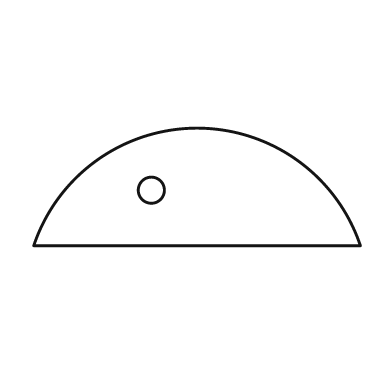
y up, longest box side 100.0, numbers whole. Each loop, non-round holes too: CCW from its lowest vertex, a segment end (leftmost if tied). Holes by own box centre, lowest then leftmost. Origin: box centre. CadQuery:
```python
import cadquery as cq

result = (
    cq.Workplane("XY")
    .moveTo(-50.0, -18.0)
    .lineTo(50.0, -18.0)
    .threePointArc((0.0, 18.0), (-50.0, -18.0))
    .close()
    .moveTo(-14.0, -1.0)
    .circle(4.0)
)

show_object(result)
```